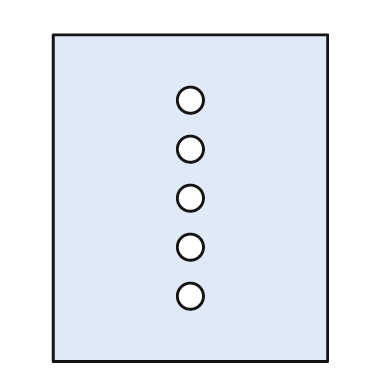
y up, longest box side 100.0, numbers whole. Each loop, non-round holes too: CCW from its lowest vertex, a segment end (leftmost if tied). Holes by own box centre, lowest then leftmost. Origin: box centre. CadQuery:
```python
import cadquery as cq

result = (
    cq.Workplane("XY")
    .moveTo(-42.0, -50.0)
    .lineTo(42.0, -50.0)
    .lineTo(42.0, 50.0)
    .lineTo(-42.0, 50.0)
    .close()
    .moveTo(0.0, -30.0)
    .circle(4.0)
    .moveTo(0.0, -15.0)
    .circle(4.0)
    .moveTo(0.0, 0.0)
    .circle(4.0)
    .moveTo(0.0, 15.0)
    .circle(4.0)
    .moveTo(0.0, 30.0)
    .circle(4.0)
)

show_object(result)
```